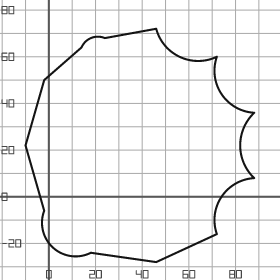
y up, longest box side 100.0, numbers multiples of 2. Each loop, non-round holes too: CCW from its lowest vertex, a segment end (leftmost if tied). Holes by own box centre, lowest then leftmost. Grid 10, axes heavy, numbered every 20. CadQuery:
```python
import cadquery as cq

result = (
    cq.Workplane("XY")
    .moveTo(46.0, -28.0)
    .lineTo(72.0, -16.0)
    .threePointArc((74.0, 0.0), (88.0, 8.0))
    .threePointArc((82.0, 22.0), (88.0, 36.0))
    .threePointArc((74.0, 44.0), (72.0, 60.0))
    .threePointArc((56.0, 60.0), (46.0, 72.0))
    .lineTo(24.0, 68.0)
    .threePointArc((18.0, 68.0), (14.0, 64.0))
    .lineTo(-2.0, 50.0)
    .lineTo(-10.0, 22.0)
    .lineTo(-2.0, -6.0)
    .threePointArc((2.0, -22.0), (18.0, -24.0))
    .close()
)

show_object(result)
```